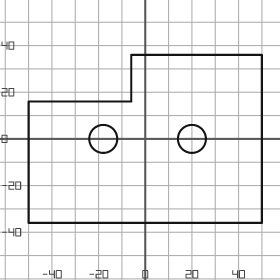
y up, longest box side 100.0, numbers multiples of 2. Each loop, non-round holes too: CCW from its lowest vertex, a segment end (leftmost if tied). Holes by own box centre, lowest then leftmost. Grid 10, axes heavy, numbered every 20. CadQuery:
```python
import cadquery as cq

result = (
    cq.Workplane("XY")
    .moveTo(-50.0, -36.0)
    .lineTo(50.0, -36.0)
    .lineTo(50.0, 36.0)
    .lineTo(-6.0, 36.0)
    .lineTo(-6.0, 16.0)
    .lineTo(-50.0, 16.0)
    .close()
    .moveTo(-18.0, 0.0)
    .circle(6.0)
    .moveTo(20.0, 0.0)
    .circle(6.0)
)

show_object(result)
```